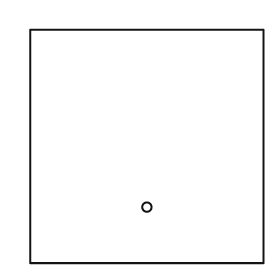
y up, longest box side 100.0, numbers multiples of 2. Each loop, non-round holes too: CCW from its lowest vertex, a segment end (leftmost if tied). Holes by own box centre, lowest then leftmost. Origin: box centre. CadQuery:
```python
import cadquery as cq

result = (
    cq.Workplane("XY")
    .moveTo(-50.0, -50.0)
    .lineTo(50.0, -50.0)
    .lineTo(50.0, 50.0)
    .lineTo(-50.0, 50.0)
    .close()
    .moveTo(0.0, -26.0)
    .circle(2.0)
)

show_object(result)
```